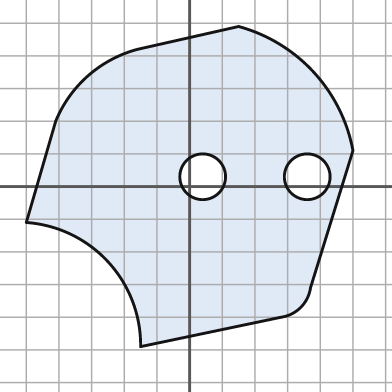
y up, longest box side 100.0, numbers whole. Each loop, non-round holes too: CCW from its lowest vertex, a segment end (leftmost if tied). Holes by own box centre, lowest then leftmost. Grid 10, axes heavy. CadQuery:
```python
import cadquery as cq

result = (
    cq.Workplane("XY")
    .moveTo(-15.0, -49.0)
    .lineTo(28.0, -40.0)
    .threePointArc((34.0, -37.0), (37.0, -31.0))
    .lineTo(50.0, 11.0)
    .threePointArc((38.0, 35.0), (15.0, 49.0))
    .lineTo(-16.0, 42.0)
    .threePointArc((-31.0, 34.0), (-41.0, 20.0))
    .lineTo(-50.0, -11.0)
    .threePointArc((-25.0, -23.0), (-15.0, -49.0))
    .close()
    .moveTo(4.0, 3.0)
    .circle(7.0)
    .moveTo(36.0, 3.0)
    .circle(7.0)
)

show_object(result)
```